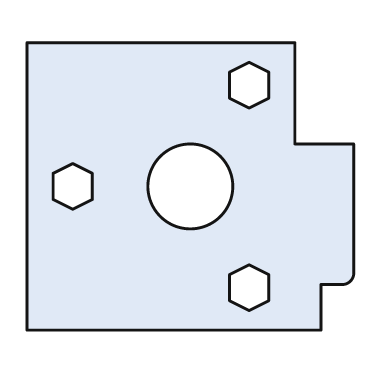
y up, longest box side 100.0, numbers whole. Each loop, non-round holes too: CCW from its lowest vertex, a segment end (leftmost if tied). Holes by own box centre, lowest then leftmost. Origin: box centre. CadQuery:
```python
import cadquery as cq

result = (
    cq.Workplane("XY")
    .moveTo(-50.0, -44.0)
    .lineTo(40.0, -44.0)
    .lineTo(40.0, -30.0)
    .lineTo(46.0, -30.0)
    .threePointArc((49.0, -29.0), (50.0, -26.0))
    .lineTo(50.0, 13.0)
    .lineTo(32.0, 13.0)
    .lineTo(32.0, 44.0)
    .lineTo(-50.0, 44.0)
    .close()
    .moveTo(18.0, -38.0)
    .lineTo(24.0, -35.0)
    .lineTo(24.0, -27.0)
    .lineTo(18.0, -24.0)
    .lineTo(12.0, -27.0)
    .lineTo(12.0, -35.0)
    .close()
    .moveTo(-36.0, -7.0)
    .lineTo(-30.0, -4.0)
    .lineTo(-30.0, 4.0)
    .lineTo(-36.0, 7.0)
    .lineTo(-42.0, 4.0)
    .lineTo(-42.0, -4.0)
    .close()
    .moveTo(0.0, 0.0)
    .circle(13.0)
    .moveTo(18.0, 24.0)
    .lineTo(24.0, 27.0)
    .lineTo(24.0, 35.0)
    .lineTo(18.0, 38.0)
    .lineTo(12.0, 35.0)
    .lineTo(12.0, 27.0)
    .close()
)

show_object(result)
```